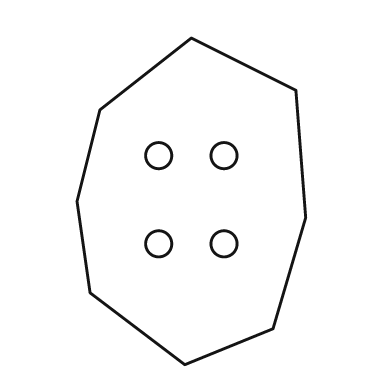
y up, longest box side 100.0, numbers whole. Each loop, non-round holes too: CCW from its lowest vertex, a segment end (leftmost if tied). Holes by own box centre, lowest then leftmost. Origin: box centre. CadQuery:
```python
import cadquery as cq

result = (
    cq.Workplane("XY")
    .moveTo(-2.0, -50.0)
    .lineTo(25.0, -39.0)
    .lineTo(35.0, -5.0)
    .lineTo(32.0, 34.0)
    .lineTo(0.0, 50.0)
    .lineTo(-28.0, 28.0)
    .lineTo(-35.0, 0.0)
    .lineTo(-31.0, -28.0)
    .close()
    .moveTo(-10.0, -13.0)
    .circle(4.0)
    .moveTo(10.0, -13.0)
    .circle(4.0)
    .moveTo(-10.0, 14.0)
    .circle(4.0)
    .moveTo(10.0, 14.0)
    .circle(4.0)
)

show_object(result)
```